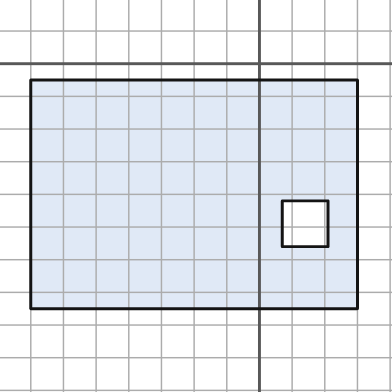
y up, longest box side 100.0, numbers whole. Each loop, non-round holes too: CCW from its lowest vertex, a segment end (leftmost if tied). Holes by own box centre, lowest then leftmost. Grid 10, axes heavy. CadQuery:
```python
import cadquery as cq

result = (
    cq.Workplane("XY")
    .moveTo(-70.0, -75.0)
    .lineTo(30.0, -75.0)
    .lineTo(30.0, -5.0)
    .lineTo(-70.0, -5.0)
    .close()
    .moveTo(7.0, -56.0)
    .lineTo(21.0, -56.0)
    .lineTo(21.0, -42.0)
    .lineTo(7.0, -42.0)
    .close()
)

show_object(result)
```